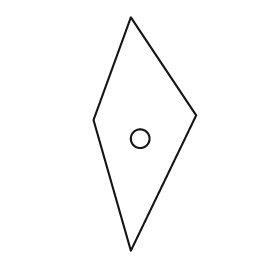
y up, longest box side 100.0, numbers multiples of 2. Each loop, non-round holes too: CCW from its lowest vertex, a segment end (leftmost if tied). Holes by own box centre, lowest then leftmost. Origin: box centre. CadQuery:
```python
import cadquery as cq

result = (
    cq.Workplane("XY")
    .moveTo(-6.0, -50.0)
    .lineTo(22.0, 8.0)
    .lineTo(-6.0, 50.0)
    .lineTo(-22.0, 6.0)
    .close()
    .moveTo(-2.0, -2.0)
    .circle(4.0)
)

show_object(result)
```